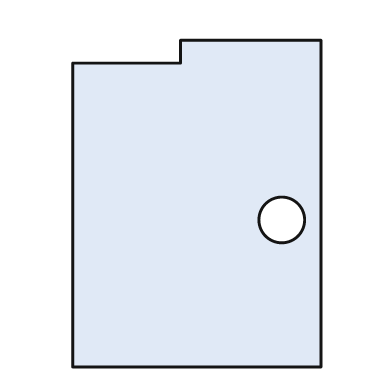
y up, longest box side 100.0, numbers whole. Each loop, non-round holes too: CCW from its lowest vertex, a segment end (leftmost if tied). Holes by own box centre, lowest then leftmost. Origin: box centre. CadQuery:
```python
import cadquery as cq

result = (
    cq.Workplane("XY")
    .moveTo(-38.0, -50.0)
    .lineTo(38.0, -50.0)
    .lineTo(38.0, 50.0)
    .lineTo(-5.0, 50.0)
    .lineTo(-5.0, 43.0)
    .lineTo(-38.0, 43.0)
    .close()
    .moveTo(26.0, -5.0)
    .circle(7.0)
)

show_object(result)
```